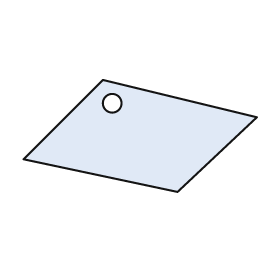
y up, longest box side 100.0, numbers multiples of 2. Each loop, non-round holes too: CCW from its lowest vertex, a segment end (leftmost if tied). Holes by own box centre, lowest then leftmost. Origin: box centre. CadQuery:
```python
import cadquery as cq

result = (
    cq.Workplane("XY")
    .moveTo(16.0, -24.0)
    .lineTo(50.0, 8.0)
    .lineTo(-16.0, 24.0)
    .lineTo(-50.0, -10.0)
    .close()
    .moveTo(-12.0, 14.0)
    .circle(4.0)
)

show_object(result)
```